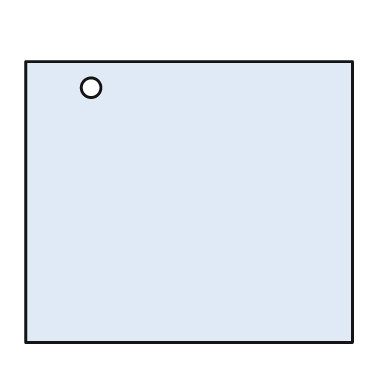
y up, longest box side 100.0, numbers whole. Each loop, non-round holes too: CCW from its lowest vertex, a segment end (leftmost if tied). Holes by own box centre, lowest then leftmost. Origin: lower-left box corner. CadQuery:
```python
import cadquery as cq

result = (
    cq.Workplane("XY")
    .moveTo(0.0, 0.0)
    .lineTo(100.0, 0.0)
    .lineTo(100.0, 86.0)
    .lineTo(0.0, 86.0)
    .close()
    .moveTo(20.0, 78.0)
    .circle(3.0)
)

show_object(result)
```